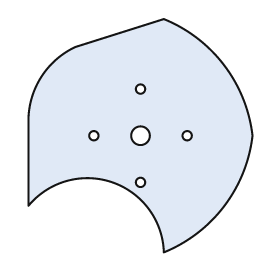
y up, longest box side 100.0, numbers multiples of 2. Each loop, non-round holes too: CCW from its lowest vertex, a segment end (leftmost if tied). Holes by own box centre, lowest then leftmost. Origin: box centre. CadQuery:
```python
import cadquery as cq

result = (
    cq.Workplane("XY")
    .moveTo(10.0, -50.0)
    .threePointArc((36.0, -30.0), (48.0, 0.0))
    .threePointArc((36.0, 30.0), (10.0, 50.0))
    .lineTo(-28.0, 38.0)
    .threePointArc((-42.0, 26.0), (-48.0, 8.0))
    .lineTo(-48.0, -30.0)
    .threePointArc((-12.0, -20.0), (10.0, -50.0))
    .close()
    .moveTo(0.0, -20.0)
    .circle(2.0)
    .moveTo(-20.0, 0.0)
    .circle(2.0)
    .moveTo(0.0, 0.0)
    .circle(4.0)
    .moveTo(20.0, 0.0)
    .circle(2.0)
    .moveTo(0.0, 20.0)
    .circle(2.0)
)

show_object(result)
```